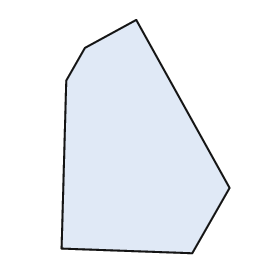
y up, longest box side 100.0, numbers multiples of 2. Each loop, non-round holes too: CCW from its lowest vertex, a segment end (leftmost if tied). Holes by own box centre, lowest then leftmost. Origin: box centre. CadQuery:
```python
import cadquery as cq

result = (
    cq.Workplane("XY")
    .moveTo(20.0, -50.0)
    .lineTo(36.0, -22.0)
    .lineTo(-4.0, 50.0)
    .lineTo(-26.0, 38.0)
    .lineTo(-34.0, 24.0)
    .lineTo(-36.0, -48.0)
    .close()
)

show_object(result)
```